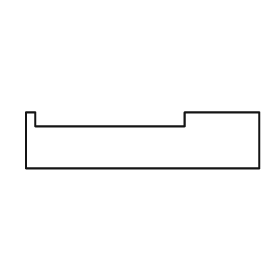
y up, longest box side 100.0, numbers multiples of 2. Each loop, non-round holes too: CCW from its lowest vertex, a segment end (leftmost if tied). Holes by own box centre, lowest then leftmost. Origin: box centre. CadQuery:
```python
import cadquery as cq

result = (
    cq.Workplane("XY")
    .moveTo(-50.0, -12.0)
    .lineTo(50.0, -12.0)
    .lineTo(50.0, 12.0)
    .lineTo(18.0, 12.0)
    .lineTo(18.0, 6.0)
    .lineTo(-46.0, 6.0)
    .lineTo(-46.0, 12.0)
    .lineTo(-50.0, 12.0)
    .close()
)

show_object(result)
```